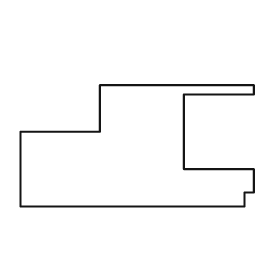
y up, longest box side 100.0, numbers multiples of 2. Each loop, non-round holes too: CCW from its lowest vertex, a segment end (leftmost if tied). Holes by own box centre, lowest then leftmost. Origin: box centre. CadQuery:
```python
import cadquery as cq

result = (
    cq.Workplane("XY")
    .moveTo(-50.0, -26.0)
    .lineTo(46.0, -26.0)
    .lineTo(46.0, -20.0)
    .lineTo(50.0, -20.0)
    .lineTo(50.0, -10.0)
    .lineTo(20.0, -10.0)
    .lineTo(20.0, 22.0)
    .lineTo(50.0, 22.0)
    .lineTo(50.0, 26.0)
    .lineTo(-16.0, 26.0)
    .lineTo(-16.0, 6.0)
    .lineTo(-50.0, 6.0)
    .close()
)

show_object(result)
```